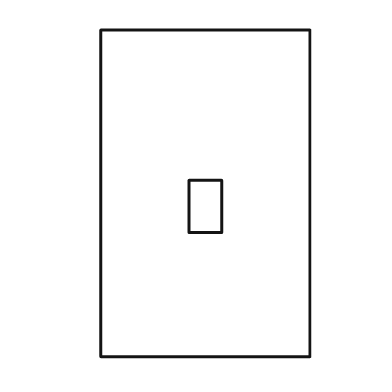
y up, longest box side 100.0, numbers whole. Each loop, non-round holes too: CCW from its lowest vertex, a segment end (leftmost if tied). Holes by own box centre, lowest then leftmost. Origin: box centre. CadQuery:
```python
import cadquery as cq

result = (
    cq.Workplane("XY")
    .moveTo(-32.0, -50.0)
    .lineTo(32.0, -50.0)
    .lineTo(32.0, 50.0)
    .lineTo(-32.0, 50.0)
    .close()
    .moveTo(-5.0, -12.0)
    .lineTo(5.0, -12.0)
    .lineTo(5.0, 4.0)
    .lineTo(-5.0, 4.0)
    .close()
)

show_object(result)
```